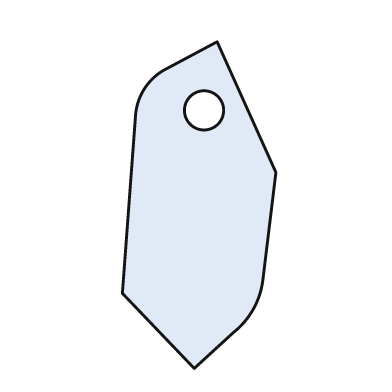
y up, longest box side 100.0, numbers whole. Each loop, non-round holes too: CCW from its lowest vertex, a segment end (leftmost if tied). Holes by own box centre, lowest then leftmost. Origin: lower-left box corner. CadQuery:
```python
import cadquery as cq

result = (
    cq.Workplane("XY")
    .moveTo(22.0, 0.0)
    .lineTo(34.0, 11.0)
    .threePointArc((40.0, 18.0), (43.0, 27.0))
    .lineTo(47.0, 60.0)
    .lineTo(29.0, 100.0)
    .lineTo(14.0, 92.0)
    .threePointArc((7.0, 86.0), (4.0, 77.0))
    .lineTo(0.0, 23.0)
    .close()
    .moveTo(25.0, 79.0)
    .circle(6.0)
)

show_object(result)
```